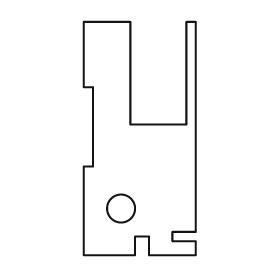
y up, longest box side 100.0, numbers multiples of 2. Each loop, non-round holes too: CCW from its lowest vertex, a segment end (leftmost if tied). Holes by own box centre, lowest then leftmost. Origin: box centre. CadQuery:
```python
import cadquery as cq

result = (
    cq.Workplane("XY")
    .moveTo(-24.0, -50.0)
    .lineTo(-2.0, -50.0)
    .lineTo(-2.0, -42.0)
    .lineTo(4.0, -42.0)
    .lineTo(4.0, -50.0)
    .lineTo(24.0, -50.0)
    .lineTo(24.0, -44.0)
    .lineTo(14.0, -44.0)
    .lineTo(14.0, -40.0)
    .lineTo(24.0, -40.0)
    .lineTo(24.0, 50.0)
    .lineTo(20.0, 50.0)
    .lineTo(20.0, 6.0)
    .lineTo(-4.0, 6.0)
    .lineTo(-4.0, 50.0)
    .lineTo(-24.0, 50.0)
    .lineTo(-24.0, 22.0)
    .lineTo(-20.0, 22.0)
    .lineTo(-20.0, -12.0)
    .lineTo(-24.0, -12.0)
    .close()
    .moveTo(-8.0, -30.0)
    .circle(6.0)
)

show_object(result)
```